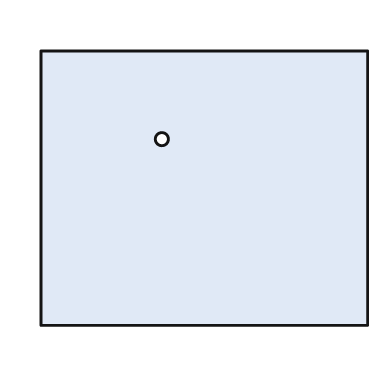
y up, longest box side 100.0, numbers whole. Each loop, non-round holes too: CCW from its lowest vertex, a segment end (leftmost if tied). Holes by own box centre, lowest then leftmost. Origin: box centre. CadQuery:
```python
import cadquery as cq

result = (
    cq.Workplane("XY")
    .moveTo(-50.0, -42.0)
    .lineTo(50.0, -42.0)
    .lineTo(50.0, 42.0)
    .lineTo(-50.0, 42.0)
    .close()
    .moveTo(-13.0, 15.0)
    .circle(2.0)
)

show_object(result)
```